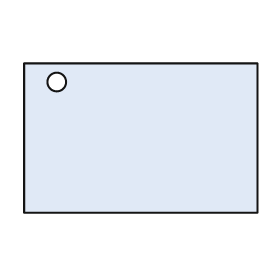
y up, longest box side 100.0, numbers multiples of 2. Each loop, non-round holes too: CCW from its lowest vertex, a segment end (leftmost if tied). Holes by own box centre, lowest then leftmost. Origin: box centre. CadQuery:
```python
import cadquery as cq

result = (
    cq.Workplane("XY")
    .moveTo(-50.0, -32.0)
    .lineTo(50.0, -32.0)
    .lineTo(50.0, 32.0)
    .lineTo(-50.0, 32.0)
    .close()
    .moveTo(-36.0, 24.0)
    .circle(4.0)
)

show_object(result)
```